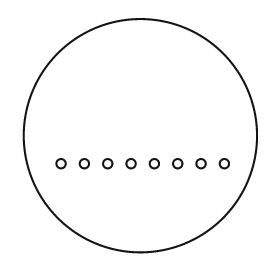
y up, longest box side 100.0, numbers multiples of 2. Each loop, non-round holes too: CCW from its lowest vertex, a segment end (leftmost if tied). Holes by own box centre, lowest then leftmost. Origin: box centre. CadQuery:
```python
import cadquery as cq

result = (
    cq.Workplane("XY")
    .moveTo(0.0, 0.0)
    .circle(50.0)
    .moveTo(-34.0, -12.0)
    .circle(2.0)
    .moveTo(-24.0, -12.0)
    .circle(2.0)
    .moveTo(-14.0, -12.0)
    .circle(2.0)
    .moveTo(-4.0, -12.0)
    .circle(2.0)
    .moveTo(6.0, -12.0)
    .circle(2.0)
    .moveTo(16.0, -12.0)
    .circle(2.0)
    .moveTo(26.0, -12.0)
    .circle(2.0)
    .moveTo(36.0, -12.0)
    .circle(2.0)
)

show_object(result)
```